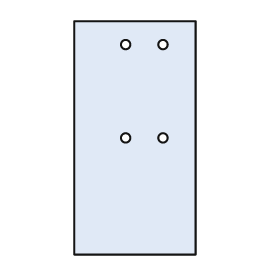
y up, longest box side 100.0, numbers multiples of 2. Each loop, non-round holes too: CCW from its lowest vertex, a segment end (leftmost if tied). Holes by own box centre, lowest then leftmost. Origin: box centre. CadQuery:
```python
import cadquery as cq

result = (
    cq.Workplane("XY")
    .moveTo(-26.0, -50.0)
    .lineTo(26.0, -50.0)
    .lineTo(26.0, 50.0)
    .lineTo(-26.0, 50.0)
    .close()
    .moveTo(-4.0, 0.0)
    .circle(2.0)
    .moveTo(12.0, 0.0)
    .circle(2.0)
    .moveTo(-4.0, 40.0)
    .circle(2.0)
    .moveTo(12.0, 40.0)
    .circle(2.0)
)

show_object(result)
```